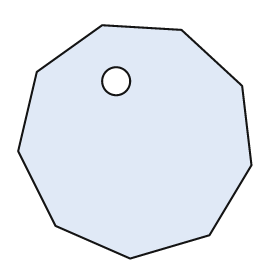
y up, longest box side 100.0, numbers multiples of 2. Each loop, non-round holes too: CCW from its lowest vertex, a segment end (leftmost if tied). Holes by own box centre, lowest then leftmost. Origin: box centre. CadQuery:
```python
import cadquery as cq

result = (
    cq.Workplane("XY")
    .moveTo(-2.0, -50.0)
    .lineTo(32.0, -40.0)
    .lineTo(50.0, -10.0)
    .lineTo(46.0, 24.0)
    .lineTo(20.0, 48.0)
    .lineTo(-14.0, 50.0)
    .lineTo(-42.0, 30.0)
    .lineTo(-50.0, -4.0)
    .lineTo(-34.0, -36.0)
    .close()
    .moveTo(-8.0, 26.0)
    .circle(6.0)
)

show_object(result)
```